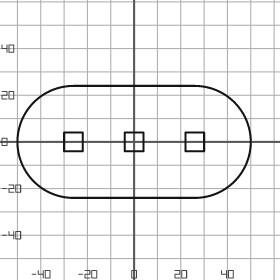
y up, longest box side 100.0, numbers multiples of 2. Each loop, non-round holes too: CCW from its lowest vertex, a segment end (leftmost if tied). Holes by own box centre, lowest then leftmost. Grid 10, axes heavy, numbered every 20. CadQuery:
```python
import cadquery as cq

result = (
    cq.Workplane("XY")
    .moveTo(-26.0, -24.0)
    .lineTo(26.0, -24.0)
    .threePointArc((50.0, 0.0), (26.0, 24.0))
    .lineTo(-26.0, 24.0)
    .threePointArc((-50.0, 0.0), (-26.0, -24.0))
    .close()
    .moveTo(-30.0, -4.0)
    .lineTo(-22.0, -4.0)
    .lineTo(-22.0, 4.0)
    .lineTo(-30.0, 4.0)
    .close()
    .moveTo(-4.0, -4.0)
    .lineTo(4.0, -4.0)
    .lineTo(4.0, 4.0)
    .lineTo(-4.0, 4.0)
    .close()
    .moveTo(22.0, -4.0)
    .lineTo(30.0, -4.0)
    .lineTo(30.0, 4.0)
    .lineTo(22.0, 4.0)
    .close()
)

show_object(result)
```